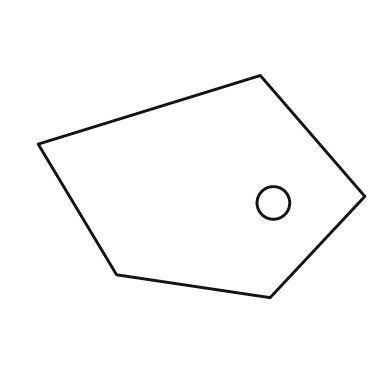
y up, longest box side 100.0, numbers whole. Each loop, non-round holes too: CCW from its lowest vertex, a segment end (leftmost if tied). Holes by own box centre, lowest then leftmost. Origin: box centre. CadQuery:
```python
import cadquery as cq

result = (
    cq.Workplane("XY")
    .moveTo(21.0, -34.0)
    .lineTo(50.0, -3.0)
    .lineTo(18.0, 34.0)
    .lineTo(-50.0, 13.0)
    .lineTo(-26.0, -27.0)
    .close()
    .moveTo(22.0, -5.0)
    .circle(5.0)
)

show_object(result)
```